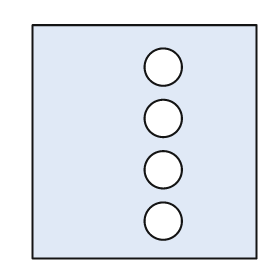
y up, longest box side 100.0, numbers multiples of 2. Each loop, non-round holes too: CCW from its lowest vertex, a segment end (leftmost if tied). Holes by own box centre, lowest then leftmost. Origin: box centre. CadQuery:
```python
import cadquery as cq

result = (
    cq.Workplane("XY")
    .moveTo(-48.0, -50.0)
    .lineTo(48.0, -50.0)
    .lineTo(48.0, 50.0)
    .lineTo(-48.0, 50.0)
    .close()
    .moveTo(8.0, -34.0)
    .circle(8.0)
    .moveTo(8.0, -12.0)
    .circle(8.0)
    .moveTo(8.0, 10.0)
    .circle(8.0)
    .moveTo(8.0, 32.0)
    .circle(8.0)
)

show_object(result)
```